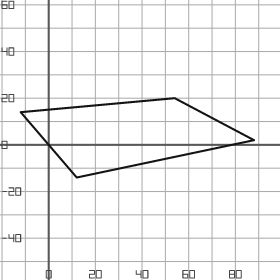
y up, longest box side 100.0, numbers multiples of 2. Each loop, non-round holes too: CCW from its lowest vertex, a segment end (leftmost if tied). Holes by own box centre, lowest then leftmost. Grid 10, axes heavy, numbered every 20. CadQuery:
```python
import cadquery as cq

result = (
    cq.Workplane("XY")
    .moveTo(12.0, -14.0)
    .lineTo(88.0, 2.0)
    .lineTo(54.0, 20.0)
    .lineTo(-12.0, 14.0)
    .close()
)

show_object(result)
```